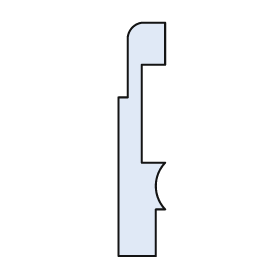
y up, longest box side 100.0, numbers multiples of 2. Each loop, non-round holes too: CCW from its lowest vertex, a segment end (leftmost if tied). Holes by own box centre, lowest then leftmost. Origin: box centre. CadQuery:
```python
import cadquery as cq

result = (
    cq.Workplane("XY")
    .moveTo(-10.0, -50.0)
    .lineTo(6.0, -50.0)
    .lineTo(6.0, -30.0)
    .lineTo(10.0, -30.0)
    .threePointArc((6.0, -20.0), (10.0, -10.0))
    .lineTo(0.0, -10.0)
    .lineTo(0.0, 32.0)
    .lineTo(10.0, 32.0)
    .lineTo(10.0, 50.0)
    .lineTo(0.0, 50.0)
    .threePointArc((-4.0, 48.0), (-6.0, 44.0))
    .lineTo(-6.0, 18.0)
    .lineTo(-10.0, 18.0)
    .close()
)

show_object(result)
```